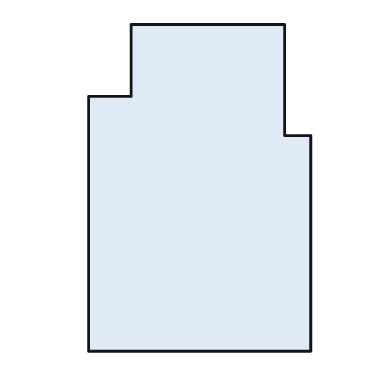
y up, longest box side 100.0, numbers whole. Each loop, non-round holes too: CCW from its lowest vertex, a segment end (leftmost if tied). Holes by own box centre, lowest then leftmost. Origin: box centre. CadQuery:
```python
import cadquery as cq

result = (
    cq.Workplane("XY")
    .moveTo(-34.0, -50.0)
    .lineTo(34.0, -50.0)
    .lineTo(34.0, 16.0)
    .lineTo(26.0, 16.0)
    .lineTo(26.0, 50.0)
    .lineTo(-21.0, 50.0)
    .lineTo(-21.0, 28.0)
    .lineTo(-34.0, 28.0)
    .close()
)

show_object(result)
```